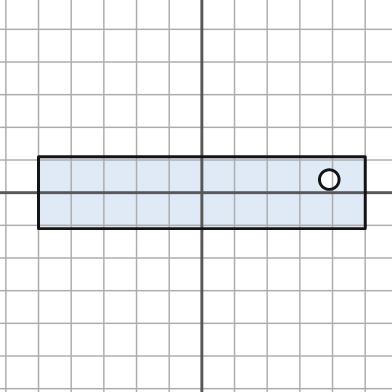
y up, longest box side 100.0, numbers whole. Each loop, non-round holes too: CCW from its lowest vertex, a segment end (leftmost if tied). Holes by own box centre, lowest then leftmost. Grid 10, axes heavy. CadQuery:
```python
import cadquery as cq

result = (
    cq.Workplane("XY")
    .moveTo(-50.0, -11.0)
    .lineTo(50.0, -11.0)
    .lineTo(50.0, 11.0)
    .lineTo(-50.0, 11.0)
    .close()
    .moveTo(39.0, 4.0)
    .circle(3.0)
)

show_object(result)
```